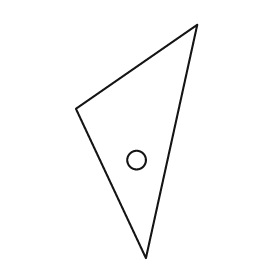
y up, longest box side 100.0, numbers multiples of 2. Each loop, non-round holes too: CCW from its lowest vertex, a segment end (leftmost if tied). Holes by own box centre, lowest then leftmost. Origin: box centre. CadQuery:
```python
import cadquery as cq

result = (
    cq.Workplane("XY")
    .moveTo(4.0, -50.0)
    .lineTo(26.0, 50.0)
    .lineTo(-26.0, 14.0)
    .close()
    .moveTo(0.0, -8.0)
    .circle(4.0)
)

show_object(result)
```